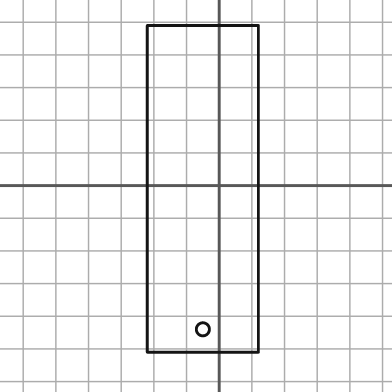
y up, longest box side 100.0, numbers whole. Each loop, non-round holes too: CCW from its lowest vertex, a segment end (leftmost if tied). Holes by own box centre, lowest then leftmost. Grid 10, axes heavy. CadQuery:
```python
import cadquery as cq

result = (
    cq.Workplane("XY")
    .moveTo(-22.0, -51.0)
    .lineTo(12.0, -51.0)
    .lineTo(12.0, 49.0)
    .lineTo(-22.0, 49.0)
    .close()
    .moveTo(-5.0, -44.0)
    .circle(2.0)
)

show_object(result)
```